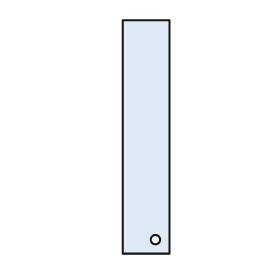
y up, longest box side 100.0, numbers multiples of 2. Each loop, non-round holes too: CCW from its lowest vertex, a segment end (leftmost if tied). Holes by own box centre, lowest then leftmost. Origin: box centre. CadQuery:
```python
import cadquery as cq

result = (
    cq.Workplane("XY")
    .moveTo(-10.0, -50.0)
    .lineTo(10.0, -50.0)
    .lineTo(10.0, 50.0)
    .lineTo(-10.0, 50.0)
    .close()
    .moveTo(4.0, -44.0)
    .circle(2.0)
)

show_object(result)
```